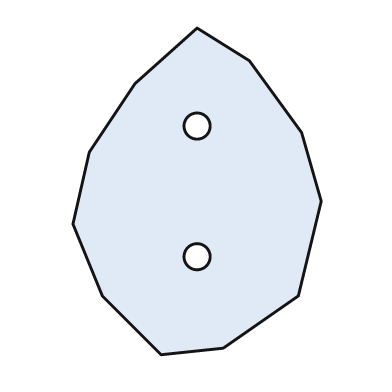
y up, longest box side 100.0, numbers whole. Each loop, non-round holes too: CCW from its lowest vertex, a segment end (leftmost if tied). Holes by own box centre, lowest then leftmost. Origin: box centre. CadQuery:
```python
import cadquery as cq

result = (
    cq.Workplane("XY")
    .moveTo(-11.0, -50.0)
    .lineTo(8.0, -48.0)
    .lineTo(31.0, -32.0)
    .lineTo(38.0, -3.0)
    .lineTo(32.0, 18.0)
    .lineTo(16.0, 40.0)
    .lineTo(0.0, 50.0)
    .lineTo(-19.0, 33.0)
    .lineTo(-33.0, 12.0)
    .lineTo(-38.0, -10.0)
    .lineTo(-29.0, -32.0)
    .close()
    .moveTo(0.0, -20.0)
    .circle(4.0)
    .moveTo(0.0, 20.0)
    .circle(4.0)
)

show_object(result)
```